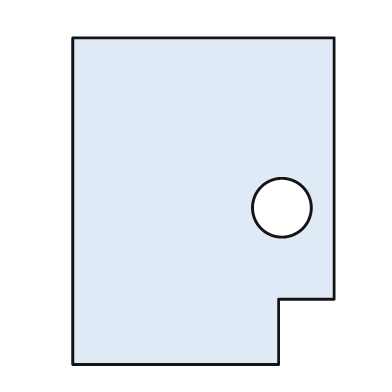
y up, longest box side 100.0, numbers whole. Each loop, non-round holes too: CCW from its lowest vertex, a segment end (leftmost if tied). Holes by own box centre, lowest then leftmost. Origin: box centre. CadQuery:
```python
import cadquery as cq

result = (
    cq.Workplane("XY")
    .moveTo(-40.0, -50.0)
    .lineTo(23.0, -50.0)
    .lineTo(23.0, -30.0)
    .lineTo(40.0, -30.0)
    .lineTo(40.0, 50.0)
    .lineTo(-40.0, 50.0)
    .close()
    .moveTo(24.0, -2.0)
    .circle(9.0)
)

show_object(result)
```